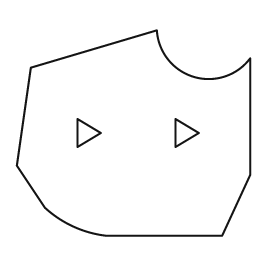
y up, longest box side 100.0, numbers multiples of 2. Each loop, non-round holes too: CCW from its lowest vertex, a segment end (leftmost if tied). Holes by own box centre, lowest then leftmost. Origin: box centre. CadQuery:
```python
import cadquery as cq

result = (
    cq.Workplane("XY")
    .moveTo(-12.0, -44.0)
    .lineTo(38.0, -44.0)
    .lineTo(50.0, -18.0)
    .lineTo(50.0, 32.0)
    .threePointArc((26.0, 24.0), (10.0, 44.0))
    .lineTo(-44.0, 28.0)
    .lineTo(-50.0, -14.0)
    .lineTo(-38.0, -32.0)
    .threePointArc((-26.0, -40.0), (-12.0, -44.0))
    .close()
    .moveTo(-24.0, -6.0)
    .lineTo(-14.0, 0.0)
    .lineTo(-24.0, 6.0)
    .close()
    .moveTo(18.0, -6.0)
    .lineTo(28.0, 0.0)
    .lineTo(18.0, 6.0)
    .close()
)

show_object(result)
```